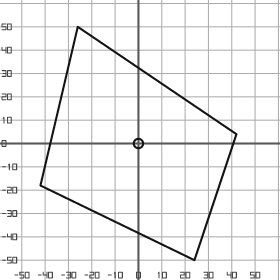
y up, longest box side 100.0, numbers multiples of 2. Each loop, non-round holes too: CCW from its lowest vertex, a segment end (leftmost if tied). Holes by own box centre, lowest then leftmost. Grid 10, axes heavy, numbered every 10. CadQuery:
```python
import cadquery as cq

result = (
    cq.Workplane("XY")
    .moveTo(24.0, -50.0)
    .lineTo(42.0, 4.0)
    .lineTo(-26.0, 50.0)
    .lineTo(-42.0, -18.0)
    .close()
    .moveTo(0.0, 0.0)
    .circle(2.0)
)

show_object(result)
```